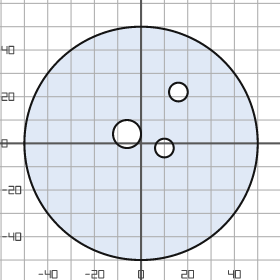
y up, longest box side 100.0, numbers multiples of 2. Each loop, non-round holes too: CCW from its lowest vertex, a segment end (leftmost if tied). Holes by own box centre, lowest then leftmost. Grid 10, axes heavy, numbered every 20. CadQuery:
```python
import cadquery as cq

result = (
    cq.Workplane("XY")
    .moveTo(0.0, 0.0)
    .circle(50.0)
    .moveTo(10.0, -2.0)
    .circle(4.0)
    .moveTo(-6.0, 4.0)
    .circle(6.0)
    .moveTo(16.0, 22.0)
    .circle(4.0)
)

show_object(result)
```